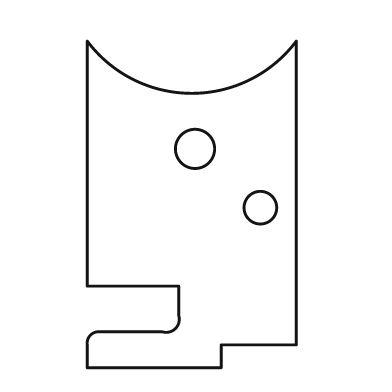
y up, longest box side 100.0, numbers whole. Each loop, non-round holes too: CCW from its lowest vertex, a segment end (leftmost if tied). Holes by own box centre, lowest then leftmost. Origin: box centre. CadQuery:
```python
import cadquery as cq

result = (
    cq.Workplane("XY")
    .moveTo(-32.0, -50.0)
    .lineTo(9.0, -50.0)
    .lineTo(9.0, -43.0)
    .lineTo(32.0, -43.0)
    .lineTo(32.0, 50.0)
    .threePointArc((0.0, 34.0), (-32.0, 50.0))
    .lineTo(-32.0, -25.0)
    .lineTo(-4.0, -25.0)
    .lineTo(-4.0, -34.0)
    .threePointArc((-5.0, -38.0), (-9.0, -39.0))
    .lineTo(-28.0, -39.0)
    .threePointArc((-31.0, -40.0), (-32.0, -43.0))
    .close()
    .moveTo(21.0, -1.0)
    .circle(5.0)
    .moveTo(1.0, 17.0)
    .circle(6.0)
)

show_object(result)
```